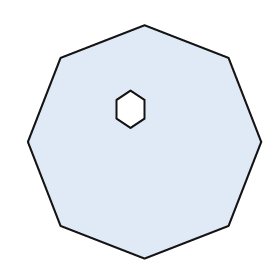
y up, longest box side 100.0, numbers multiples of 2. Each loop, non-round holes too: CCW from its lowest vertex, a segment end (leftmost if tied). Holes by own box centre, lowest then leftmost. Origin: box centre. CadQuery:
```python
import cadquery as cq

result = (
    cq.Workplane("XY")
    .moveTo(0.0, -50.0)
    .lineTo(36.0, -36.0)
    .lineTo(50.0, 0.0)
    .lineTo(36.0, 36.0)
    .lineTo(0.0, 50.0)
    .lineTo(-36.0, 36.0)
    .lineTo(-50.0, 0.0)
    .lineTo(-36.0, -36.0)
    .close()
    .moveTo(-6.0, 6.0)
    .lineTo(0.0, 10.0)
    .lineTo(0.0, 18.0)
    .lineTo(-6.0, 22.0)
    .lineTo(-12.0, 18.0)
    .lineTo(-12.0, 10.0)
    .close()
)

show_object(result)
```